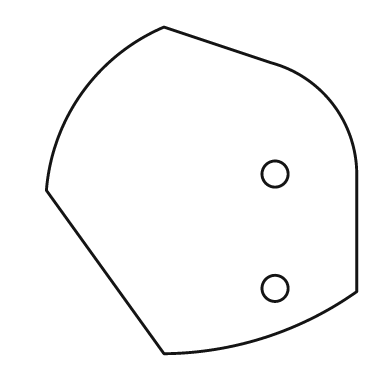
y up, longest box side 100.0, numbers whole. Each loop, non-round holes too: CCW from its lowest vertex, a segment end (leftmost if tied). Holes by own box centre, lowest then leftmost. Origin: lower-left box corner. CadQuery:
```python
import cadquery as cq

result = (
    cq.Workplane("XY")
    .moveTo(36.0, 0.0)
    .threePointArc((67.0, 5.0), (95.0, 19.0))
    .lineTo(95.0, 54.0)
    .threePointArc((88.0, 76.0), (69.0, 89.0))
    .lineTo(36.0, 100.0)
    .threePointArc((11.0, 80.0), (0.0, 50.0))
    .close()
    .moveTo(70.0, 20.0)
    .circle(4.0)
    .moveTo(70.0, 55.0)
    .circle(4.0)
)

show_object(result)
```